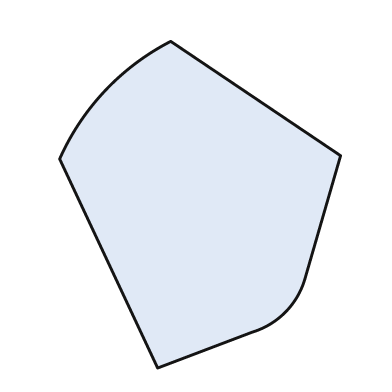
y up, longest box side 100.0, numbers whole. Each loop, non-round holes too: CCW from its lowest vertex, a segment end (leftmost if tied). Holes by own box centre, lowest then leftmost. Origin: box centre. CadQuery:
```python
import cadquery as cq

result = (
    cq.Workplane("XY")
    .moveTo(-13.0, -50.0)
    .lineTo(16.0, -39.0)
    .threePointArc((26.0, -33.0), (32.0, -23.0))
    .lineTo(43.0, 15.0)
    .lineTo(-9.0, 50.0)
    .threePointArc((-29.0, 35.0), (-43.0, 14.0))
    .close()
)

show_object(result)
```